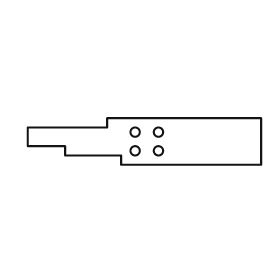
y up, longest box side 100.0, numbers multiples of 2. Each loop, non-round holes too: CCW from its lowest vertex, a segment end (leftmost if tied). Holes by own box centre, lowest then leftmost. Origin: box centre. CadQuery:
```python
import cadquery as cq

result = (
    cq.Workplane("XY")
    .moveTo(-10.0, -10.0)
    .lineTo(50.0, -10.0)
    .lineTo(50.0, 10.0)
    .lineTo(-16.0, 10.0)
    .lineTo(-16.0, 6.0)
    .lineTo(-50.0, 6.0)
    .lineTo(-50.0, -2.0)
    .lineTo(-34.0, -2.0)
    .lineTo(-34.0, -6.0)
    .lineTo(-10.0, -6.0)
    .close()
    .moveTo(-4.0, -4.0)
    .circle(2.0)
    .moveTo(6.0, -4.0)
    .circle(2.0)
    .moveTo(-4.0, 4.0)
    .circle(2.0)
    .moveTo(6.0, 4.0)
    .circle(2.0)
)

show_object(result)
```